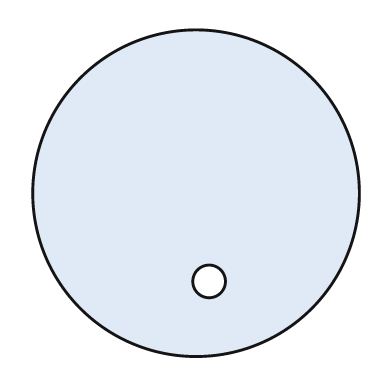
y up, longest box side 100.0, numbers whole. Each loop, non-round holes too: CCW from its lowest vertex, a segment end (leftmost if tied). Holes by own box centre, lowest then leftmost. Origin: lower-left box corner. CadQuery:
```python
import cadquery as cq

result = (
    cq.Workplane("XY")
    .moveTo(50.0, 50.0)
    .circle(50.0)
    .moveTo(54.0, 23.0)
    .circle(5.0)
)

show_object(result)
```